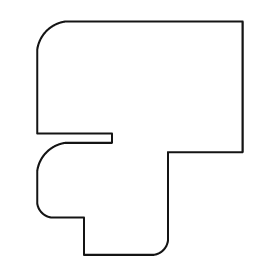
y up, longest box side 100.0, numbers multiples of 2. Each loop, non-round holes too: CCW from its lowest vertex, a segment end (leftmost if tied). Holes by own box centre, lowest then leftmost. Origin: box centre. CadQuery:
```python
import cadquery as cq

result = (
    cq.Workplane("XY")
    .moveTo(-24.0, -50.0)
    .lineTo(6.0, -50.0)
    .threePointArc((10.0, -48.0), (12.0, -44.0))
    .lineTo(12.0, -6.0)
    .lineTo(44.0, -6.0)
    .lineTo(44.0, 50.0)
    .lineTo(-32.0, 50.0)
    .threePointArc((-40.0, 46.0), (-44.0, 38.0))
    .lineTo(-44.0, 2.0)
    .lineTo(-12.0, 2.0)
    .lineTo(-12.0, -2.0)
    .lineTo(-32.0, -2.0)
    .threePointArc((-40.0, -6.0), (-44.0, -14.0))
    .lineTo(-44.0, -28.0)
    .threePointArc((-42.0, -32.0), (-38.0, -34.0))
    .lineTo(-24.0, -34.0)
    .close()
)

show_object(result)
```